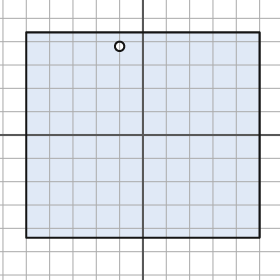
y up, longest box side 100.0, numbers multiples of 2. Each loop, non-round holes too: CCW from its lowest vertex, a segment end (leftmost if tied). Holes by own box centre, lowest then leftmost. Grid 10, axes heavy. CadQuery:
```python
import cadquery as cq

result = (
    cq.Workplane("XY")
    .moveTo(-50.0, -44.0)
    .lineTo(50.0, -44.0)
    .lineTo(50.0, 44.0)
    .lineTo(-50.0, 44.0)
    .close()
    .moveTo(-10.0, 38.0)
    .circle(2.0)
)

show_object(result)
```